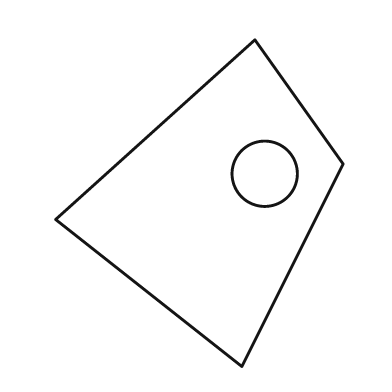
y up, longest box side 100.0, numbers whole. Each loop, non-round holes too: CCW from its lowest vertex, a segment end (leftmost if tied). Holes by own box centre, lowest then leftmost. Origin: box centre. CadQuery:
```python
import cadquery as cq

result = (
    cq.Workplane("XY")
    .moveTo(13.0, -50.0)
    .lineTo(44.0, 12.0)
    .lineTo(17.0, 50.0)
    .lineTo(-44.0, -5.0)
    .close()
    .moveTo(20.0, 9.0)
    .circle(10.0)
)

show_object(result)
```